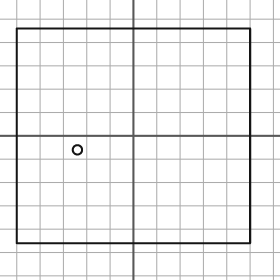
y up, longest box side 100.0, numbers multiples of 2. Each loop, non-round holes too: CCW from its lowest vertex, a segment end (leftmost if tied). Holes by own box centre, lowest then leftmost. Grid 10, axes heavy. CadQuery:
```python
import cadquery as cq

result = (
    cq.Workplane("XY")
    .moveTo(-50.0, -46.0)
    .lineTo(50.0, -46.0)
    .lineTo(50.0, 46.0)
    .lineTo(-50.0, 46.0)
    .close()
    .moveTo(-24.0, -6.0)
    .circle(2.0)
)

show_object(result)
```